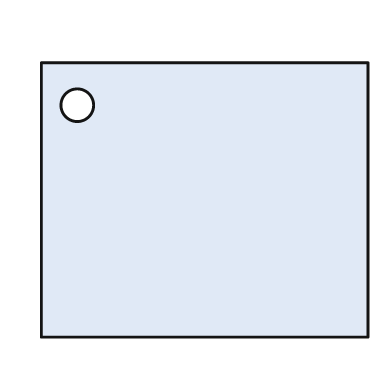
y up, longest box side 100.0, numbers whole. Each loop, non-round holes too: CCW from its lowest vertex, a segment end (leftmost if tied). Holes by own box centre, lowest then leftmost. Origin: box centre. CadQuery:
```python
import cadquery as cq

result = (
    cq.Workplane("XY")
    .moveTo(-50.0, -42.0)
    .lineTo(50.0, -42.0)
    .lineTo(50.0, 42.0)
    .lineTo(-50.0, 42.0)
    .close()
    .moveTo(-39.0, 29.0)
    .circle(5.0)
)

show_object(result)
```